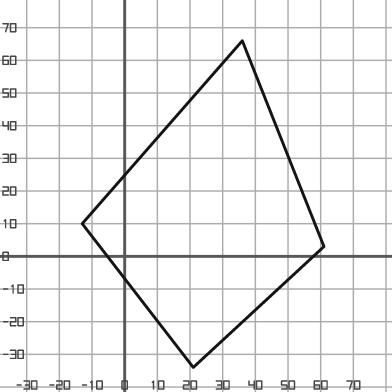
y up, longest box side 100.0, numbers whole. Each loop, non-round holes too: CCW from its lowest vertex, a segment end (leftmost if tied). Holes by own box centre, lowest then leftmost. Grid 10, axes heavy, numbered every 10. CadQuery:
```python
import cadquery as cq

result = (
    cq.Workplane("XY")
    .moveTo(21.0, -34.0)
    .lineTo(61.0, 3.0)
    .lineTo(36.0, 66.0)
    .lineTo(-13.0, 10.0)
    .close()
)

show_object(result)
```